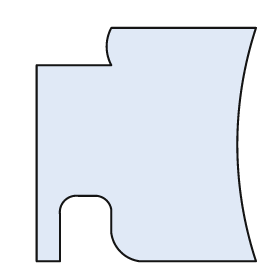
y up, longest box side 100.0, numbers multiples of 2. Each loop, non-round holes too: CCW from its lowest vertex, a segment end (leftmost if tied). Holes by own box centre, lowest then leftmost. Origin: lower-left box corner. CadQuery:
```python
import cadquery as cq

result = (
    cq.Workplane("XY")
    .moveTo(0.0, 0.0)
    .lineTo(10.0, 0.0)
    .lineTo(10.0, 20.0)
    .threePointArc((12.0, 26.0), (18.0, 28.0))
    .lineTo(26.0, 28.0)
    .threePointArc((30.0, 26.0), (32.0, 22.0))
    .lineTo(32.0, 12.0)
    .threePointArc((36.0, 4.0), (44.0, 0.0))
    .lineTo(94.0, 0.0)
    .threePointArc((86.0, 50.0), (94.0, 100.0))
    .lineTo(32.0, 100.0)
    .threePointArc((30.0, 92.0), (32.0, 84.0))
    .lineTo(0.0, 84.0)
    .close()
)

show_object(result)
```